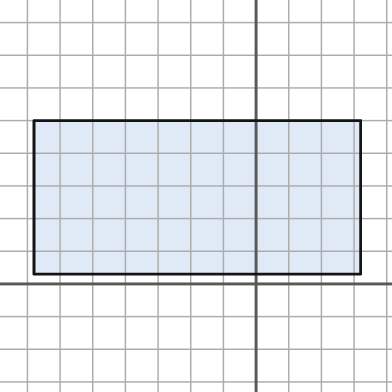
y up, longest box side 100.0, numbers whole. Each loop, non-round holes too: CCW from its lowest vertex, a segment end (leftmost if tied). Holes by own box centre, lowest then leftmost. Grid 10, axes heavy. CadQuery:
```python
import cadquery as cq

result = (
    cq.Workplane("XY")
    .moveTo(-68.0, 3.0)
    .lineTo(32.0, 3.0)
    .lineTo(32.0, 50.0)
    .lineTo(-68.0, 50.0)
    .close()
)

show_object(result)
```